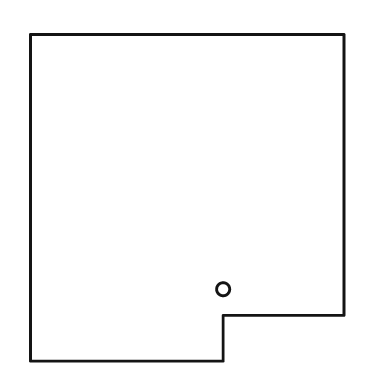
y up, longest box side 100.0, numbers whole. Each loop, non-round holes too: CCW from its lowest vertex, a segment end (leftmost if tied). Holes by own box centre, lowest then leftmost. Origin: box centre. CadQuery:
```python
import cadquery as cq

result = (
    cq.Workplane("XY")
    .moveTo(-48.0, -50.0)
    .lineTo(11.0, -50.0)
    .lineTo(11.0, -36.0)
    .lineTo(48.0, -36.0)
    .lineTo(48.0, 50.0)
    .lineTo(-48.0, 50.0)
    .close()
    .moveTo(11.0, -28.0)
    .circle(2.0)
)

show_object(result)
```